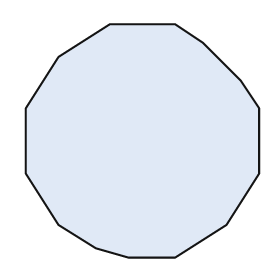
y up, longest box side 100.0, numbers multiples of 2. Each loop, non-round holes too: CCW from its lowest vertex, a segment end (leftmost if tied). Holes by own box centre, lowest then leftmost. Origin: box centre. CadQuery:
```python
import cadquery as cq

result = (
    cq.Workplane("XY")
    .moveTo(-6.0, -50.0)
    .lineTo(14.0, -50.0)
    .lineTo(36.0, -36.0)
    .lineTo(50.0, -14.0)
    .lineTo(50.0, 14.0)
    .lineTo(42.0, 26.0)
    .lineTo(26.0, 42.0)
    .lineTo(14.0, 50.0)
    .lineTo(-14.0, 50.0)
    .lineTo(-36.0, 36.0)
    .lineTo(-50.0, 14.0)
    .lineTo(-50.0, -14.0)
    .lineTo(-36.0, -36.0)
    .lineTo(-20.0, -46.0)
    .close()
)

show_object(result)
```